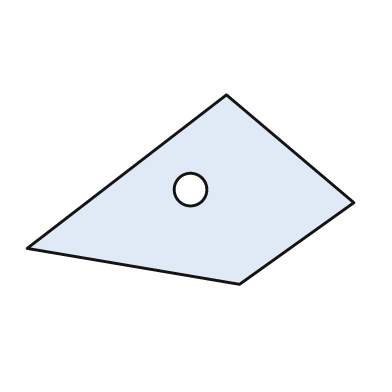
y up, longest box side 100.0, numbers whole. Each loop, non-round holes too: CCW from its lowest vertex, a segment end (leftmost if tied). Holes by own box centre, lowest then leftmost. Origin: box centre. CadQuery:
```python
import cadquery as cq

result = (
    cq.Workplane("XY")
    .moveTo(15.0, -29.0)
    .lineTo(50.0, -4.0)
    .lineTo(11.0, 29.0)
    .lineTo(-50.0, -18.0)
    .close()
    .moveTo(0.0, 0.0)
    .circle(5.0)
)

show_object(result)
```